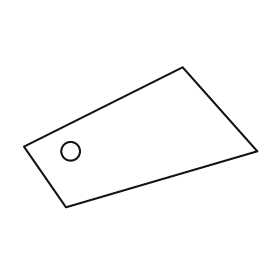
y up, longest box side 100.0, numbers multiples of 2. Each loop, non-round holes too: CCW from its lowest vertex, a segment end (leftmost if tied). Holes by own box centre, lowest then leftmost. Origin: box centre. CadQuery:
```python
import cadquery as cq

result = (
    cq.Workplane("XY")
    .moveTo(-32.0, -30.0)
    .lineTo(50.0, -6.0)
    .lineTo(18.0, 30.0)
    .lineTo(-50.0, -4.0)
    .close()
    .moveTo(-30.0, -6.0)
    .circle(4.0)
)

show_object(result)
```